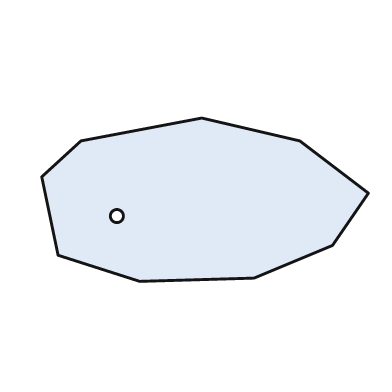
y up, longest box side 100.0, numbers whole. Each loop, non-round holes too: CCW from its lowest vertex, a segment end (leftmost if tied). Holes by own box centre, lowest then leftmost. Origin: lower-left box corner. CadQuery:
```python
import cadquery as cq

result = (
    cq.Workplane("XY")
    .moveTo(30.0, 0.0)
    .lineTo(65.0, 1.0)
    .lineTo(89.0, 11.0)
    .lineTo(100.0, 27.0)
    .lineTo(79.0, 43.0)
    .lineTo(49.0, 50.0)
    .lineTo(12.0, 43.0)
    .lineTo(0.0, 32.0)
    .lineTo(5.0, 8.0)
    .close()
    .moveTo(23.0, 20.0)
    .circle(2.0)
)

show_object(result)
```